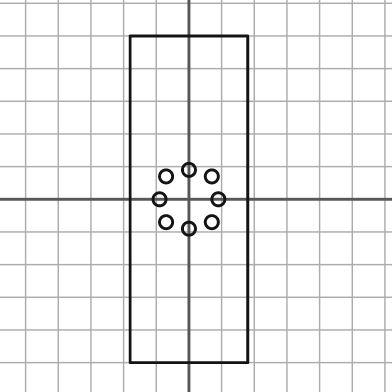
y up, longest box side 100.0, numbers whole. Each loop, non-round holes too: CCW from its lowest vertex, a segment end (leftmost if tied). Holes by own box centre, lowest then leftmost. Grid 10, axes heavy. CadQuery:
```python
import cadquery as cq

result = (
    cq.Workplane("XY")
    .moveTo(-18.0, -50.0)
    .lineTo(18.0, -50.0)
    .lineTo(18.0, 50.0)
    .lineTo(-18.0, 50.0)
    .close()
    .moveTo(0.0, -9.0)
    .circle(2.0)
    .moveTo(-7.0, -7.0)
    .circle(2.0)
    .moveTo(7.0, -7.0)
    .circle(2.0)
    .moveTo(-9.0, 0.0)
    .circle(2.0)
    .moveTo(9.0, 0.0)
    .circle(2.0)
    .moveTo(-7.0, 7.0)
    .circle(2.0)
    .moveTo(7.0, 7.0)
    .circle(2.0)
    .moveTo(0.0, 9.0)
    .circle(2.0)
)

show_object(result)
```